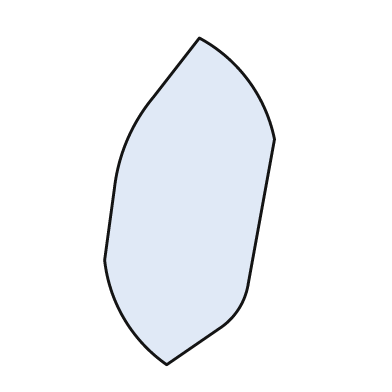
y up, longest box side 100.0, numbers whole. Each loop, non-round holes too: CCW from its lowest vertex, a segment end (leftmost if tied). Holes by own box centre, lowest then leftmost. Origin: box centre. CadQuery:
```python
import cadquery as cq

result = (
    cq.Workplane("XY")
    .moveTo(-7.0, -50.0)
    .lineTo(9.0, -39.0)
    .threePointArc((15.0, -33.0), (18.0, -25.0))
    .lineTo(26.0, 19.0)
    .threePointArc((18.0, 37.0), (3.0, 50.0))
    .lineTo(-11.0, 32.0)
    .threePointArc((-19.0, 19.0), (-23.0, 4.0))
    .lineTo(-26.0, -18.0)
    .threePointArc((-20.0, -36.0), (-7.0, -50.0))
    .close()
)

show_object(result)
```